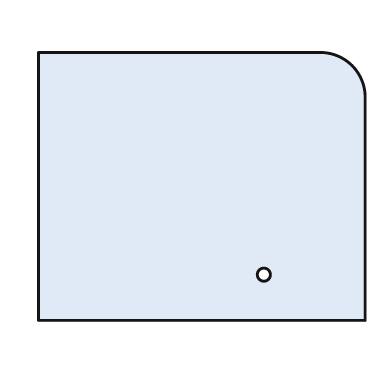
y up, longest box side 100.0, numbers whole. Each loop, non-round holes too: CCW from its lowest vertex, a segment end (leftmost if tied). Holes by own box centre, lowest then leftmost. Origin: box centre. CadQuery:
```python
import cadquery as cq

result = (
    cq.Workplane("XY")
    .moveTo(-50.0, -41.0)
    .lineTo(50.0, -41.0)
    .lineTo(50.0, 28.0)
    .threePointArc((46.0, 37.0), (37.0, 41.0))
    .lineTo(-50.0, 41.0)
    .close()
    .moveTo(19.0, -27.0)
    .circle(2.0)
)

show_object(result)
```